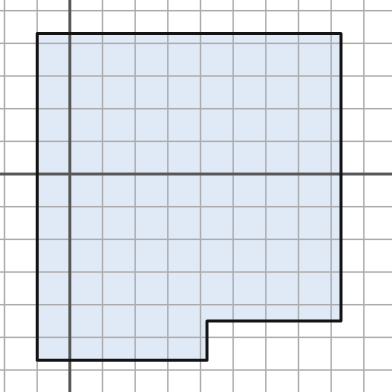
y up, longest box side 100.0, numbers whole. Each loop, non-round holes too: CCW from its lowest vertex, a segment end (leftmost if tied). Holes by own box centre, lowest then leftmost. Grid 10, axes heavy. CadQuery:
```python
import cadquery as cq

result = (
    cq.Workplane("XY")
    .moveTo(-10.0, -57.0)
    .lineTo(42.0, -57.0)
    .lineTo(42.0, -45.0)
    .lineTo(83.0, -45.0)
    .lineTo(83.0, 43.0)
    .lineTo(-10.0, 43.0)
    .close()
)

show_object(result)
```